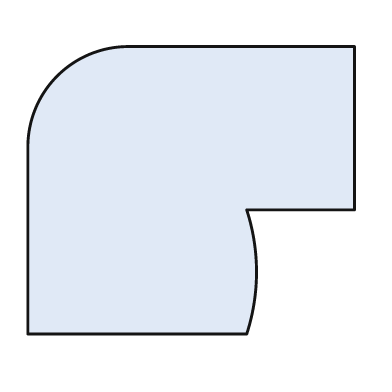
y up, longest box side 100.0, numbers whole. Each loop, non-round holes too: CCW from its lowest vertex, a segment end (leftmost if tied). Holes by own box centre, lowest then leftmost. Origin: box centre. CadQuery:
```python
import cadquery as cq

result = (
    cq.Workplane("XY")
    .moveTo(-50.0, -44.0)
    .lineTo(17.0, -44.0)
    .threePointArc((20.0, -25.0), (17.0, -6.0))
    .lineTo(50.0, -6.0)
    .lineTo(50.0, 44.0)
    .lineTo(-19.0, 44.0)
    .threePointArc((-41.0, 35.0), (-50.0, 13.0))
    .close()
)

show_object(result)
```